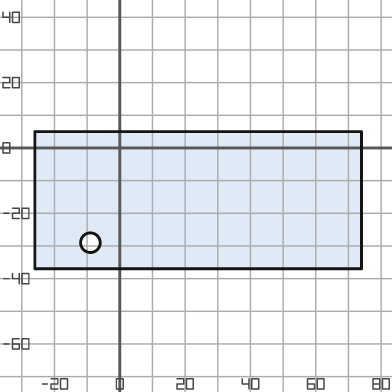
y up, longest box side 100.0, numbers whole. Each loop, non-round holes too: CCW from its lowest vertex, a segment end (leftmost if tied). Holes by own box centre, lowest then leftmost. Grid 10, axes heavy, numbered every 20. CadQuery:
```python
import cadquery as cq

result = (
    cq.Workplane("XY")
    .moveTo(-26.0, -37.0)
    .lineTo(74.0, -37.0)
    .lineTo(74.0, 5.0)
    .lineTo(-26.0, 5.0)
    .close()
    .moveTo(-9.0, -29.0)
    .circle(3.0)
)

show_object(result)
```